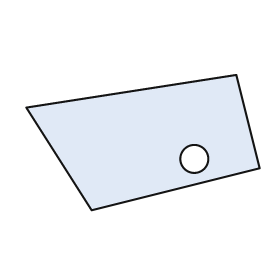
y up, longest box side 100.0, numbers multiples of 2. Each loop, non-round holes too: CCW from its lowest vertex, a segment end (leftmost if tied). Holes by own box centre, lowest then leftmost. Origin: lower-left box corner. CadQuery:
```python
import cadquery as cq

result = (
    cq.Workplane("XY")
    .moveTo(28.0, 0.0)
    .lineTo(100.0, 18.0)
    .lineTo(90.0, 58.0)
    .lineTo(0.0, 44.0)
    .close()
    .moveTo(72.0, 22.0)
    .circle(6.0)
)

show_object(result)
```